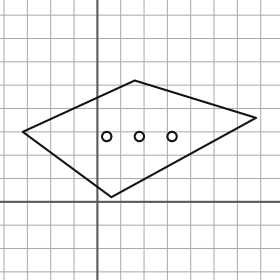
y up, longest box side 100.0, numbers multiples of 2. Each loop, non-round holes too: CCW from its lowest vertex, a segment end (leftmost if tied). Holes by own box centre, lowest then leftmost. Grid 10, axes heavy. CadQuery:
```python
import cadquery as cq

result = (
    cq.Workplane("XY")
    .moveTo(6.0, 2.0)
    .lineTo(68.0, 36.0)
    .lineTo(16.0, 52.0)
    .lineTo(-32.0, 30.0)
    .close()
    .moveTo(4.0, 28.0)
    .circle(2.0)
    .moveTo(18.0, 28.0)
    .circle(2.0)
    .moveTo(32.0, 28.0)
    .circle(2.0)
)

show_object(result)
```